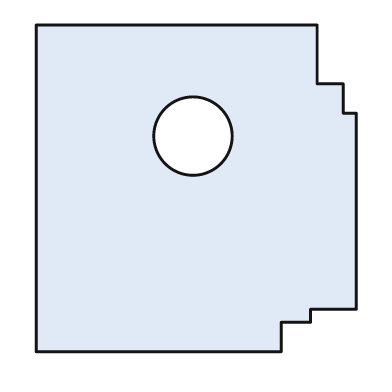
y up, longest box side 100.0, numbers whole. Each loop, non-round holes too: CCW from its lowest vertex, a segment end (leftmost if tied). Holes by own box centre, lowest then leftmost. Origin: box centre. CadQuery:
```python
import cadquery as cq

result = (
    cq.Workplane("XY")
    .moveTo(-49.0, -50.0)
    .lineTo(26.0, -50.0)
    .lineTo(26.0, -41.0)
    .lineTo(35.0, -41.0)
    .lineTo(35.0, -37.0)
    .lineTo(49.0, -37.0)
    .lineTo(49.0, 23.0)
    .lineTo(45.0, 23.0)
    .lineTo(45.0, 32.0)
    .lineTo(37.0, 32.0)
    .lineTo(37.0, 50.0)
    .lineTo(-49.0, 50.0)
    .close()
    .moveTo(-1.0, 16.0)
    .circle(12.0)
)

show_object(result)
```